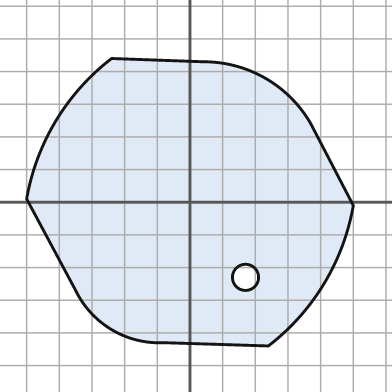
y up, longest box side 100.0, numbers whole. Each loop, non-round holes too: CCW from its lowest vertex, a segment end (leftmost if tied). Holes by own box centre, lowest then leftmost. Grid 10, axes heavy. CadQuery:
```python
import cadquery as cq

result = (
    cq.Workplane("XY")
    .moveTo(24.0, -44.0)
    .threePointArc((41.0, -25.0), (50.0, -1.0))
    .lineTo(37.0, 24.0)
    .threePointArc((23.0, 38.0), (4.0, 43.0))
    .lineTo(-24.0, 44.0)
    .threePointArc((-41.0, 25.0), (-50.0, 1.0))
    .lineTo(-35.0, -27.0)
    .threePointArc((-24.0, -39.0), (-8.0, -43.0))
    .close()
    .moveTo(17.0, -23.0)
    .circle(4.0)
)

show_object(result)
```